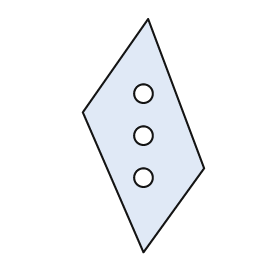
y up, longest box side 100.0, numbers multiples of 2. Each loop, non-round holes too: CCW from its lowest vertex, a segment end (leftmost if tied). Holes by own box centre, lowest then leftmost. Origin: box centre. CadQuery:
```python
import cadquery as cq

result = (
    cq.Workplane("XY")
    .moveTo(0.0, -50.0)
    .lineTo(26.0, -14.0)
    .lineTo(2.0, 50.0)
    .lineTo(-26.0, 10.0)
    .close()
    .moveTo(0.0, -18.0)
    .circle(4.0)
    .moveTo(0.0, 0.0)
    .circle(4.0)
    .moveTo(0.0, 18.0)
    .circle(4.0)
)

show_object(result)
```